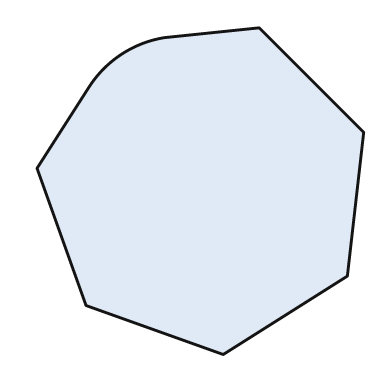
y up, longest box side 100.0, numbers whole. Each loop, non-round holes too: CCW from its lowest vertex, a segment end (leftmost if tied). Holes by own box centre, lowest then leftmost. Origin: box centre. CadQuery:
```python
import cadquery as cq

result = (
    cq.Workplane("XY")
    .moveTo(7.0, -50.0)
    .lineTo(45.0, -26.0)
    .lineTo(50.0, 18.0)
    .lineTo(18.0, 50.0)
    .lineTo(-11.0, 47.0)
    .threePointArc((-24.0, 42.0), (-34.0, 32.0))
    .lineTo(-50.0, 7.0)
    .lineTo(-35.0, -35.0)
    .close()
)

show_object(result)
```